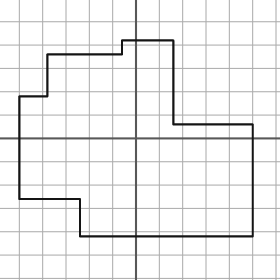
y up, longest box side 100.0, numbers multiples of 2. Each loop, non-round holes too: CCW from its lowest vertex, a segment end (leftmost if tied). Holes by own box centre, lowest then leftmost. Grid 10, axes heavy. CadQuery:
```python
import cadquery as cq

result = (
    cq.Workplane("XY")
    .moveTo(-24.0, -42.0)
    .lineTo(50.0, -42.0)
    .lineTo(50.0, 6.0)
    .lineTo(16.0, 6.0)
    .lineTo(16.0, 42.0)
    .lineTo(-6.0, 42.0)
    .lineTo(-6.0, 36.0)
    .lineTo(-38.0, 36.0)
    .lineTo(-38.0, 18.0)
    .lineTo(-50.0, 18.0)
    .lineTo(-50.0, -26.0)
    .lineTo(-24.0, -26.0)
    .close()
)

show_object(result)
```